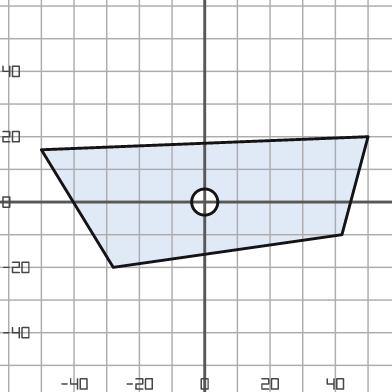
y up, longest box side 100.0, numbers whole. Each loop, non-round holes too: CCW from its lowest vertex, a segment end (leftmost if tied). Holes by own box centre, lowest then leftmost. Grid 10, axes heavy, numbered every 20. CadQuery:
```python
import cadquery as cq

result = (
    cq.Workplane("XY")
    .moveTo(-28.0, -20.0)
    .lineTo(42.0, -10.0)
    .lineTo(50.0, 20.0)
    .lineTo(-50.0, 16.0)
    .close()
    .moveTo(0.0, 0.0)
    .circle(4.0)
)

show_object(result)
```